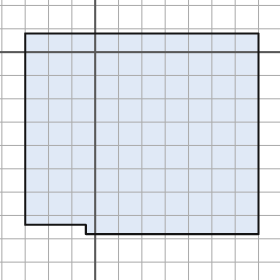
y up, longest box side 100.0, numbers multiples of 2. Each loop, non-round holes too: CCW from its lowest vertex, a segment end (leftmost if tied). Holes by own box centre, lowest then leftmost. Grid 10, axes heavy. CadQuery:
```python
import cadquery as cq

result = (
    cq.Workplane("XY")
    .moveTo(-4.0, -78.0)
    .lineTo(70.0, -78.0)
    .lineTo(70.0, 8.0)
    .lineTo(-30.0, 8.0)
    .lineTo(-30.0, -74.0)
    .lineTo(-4.0, -74.0)
    .close()
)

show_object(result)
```